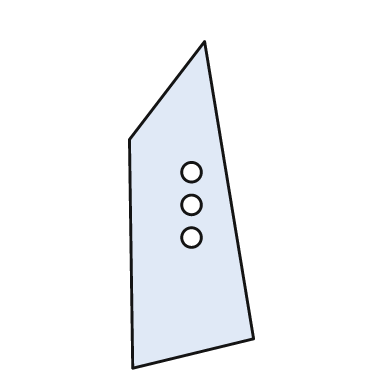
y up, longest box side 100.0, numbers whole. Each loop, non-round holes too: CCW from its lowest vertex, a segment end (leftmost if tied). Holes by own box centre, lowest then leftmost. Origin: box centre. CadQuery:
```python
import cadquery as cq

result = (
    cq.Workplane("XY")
    .moveTo(-18.0, -50.0)
    .lineTo(19.0, -41.0)
    .lineTo(4.0, 50.0)
    .lineTo(-19.0, 20.0)
    .close()
    .moveTo(0.0, -10.0)
    .circle(3.0)
    .moveTo(0.0, 0.0)
    .circle(3.0)
    .moveTo(0.0, 10.0)
    .circle(3.0)
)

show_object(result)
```